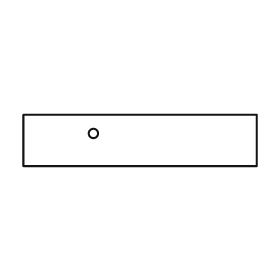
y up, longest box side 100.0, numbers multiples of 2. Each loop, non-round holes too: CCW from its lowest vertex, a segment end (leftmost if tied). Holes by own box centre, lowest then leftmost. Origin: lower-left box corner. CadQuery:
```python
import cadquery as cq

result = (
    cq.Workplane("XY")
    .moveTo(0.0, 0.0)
    .lineTo(100.0, 0.0)
    .lineTo(100.0, 22.0)
    .lineTo(0.0, 22.0)
    .close()
    .moveTo(30.0, 14.0)
    .circle(2.0)
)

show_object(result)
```